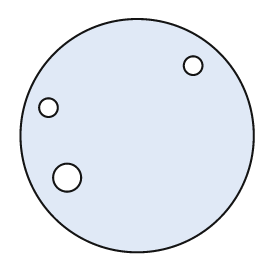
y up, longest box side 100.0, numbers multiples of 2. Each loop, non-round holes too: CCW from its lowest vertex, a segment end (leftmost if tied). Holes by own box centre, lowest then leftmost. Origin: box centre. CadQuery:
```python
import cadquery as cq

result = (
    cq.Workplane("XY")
    .moveTo(0.0, 0.0)
    .circle(50.0)
    .moveTo(-30.0, -18.0)
    .circle(6.0)
    .moveTo(-38.0, 12.0)
    .circle(4.0)
    .moveTo(24.0, 30.0)
    .circle(4.0)
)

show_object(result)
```